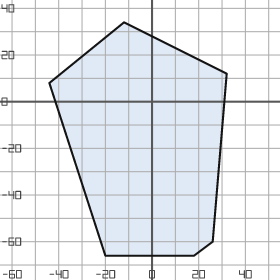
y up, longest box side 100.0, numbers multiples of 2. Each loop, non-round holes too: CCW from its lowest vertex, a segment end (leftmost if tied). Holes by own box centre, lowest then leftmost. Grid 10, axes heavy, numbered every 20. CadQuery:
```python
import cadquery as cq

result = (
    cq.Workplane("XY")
    .moveTo(-20.0, -66.0)
    .lineTo(18.0, -66.0)
    .lineTo(26.0, -60.0)
    .lineTo(32.0, 12.0)
    .lineTo(-12.0, 34.0)
    .lineTo(-44.0, 8.0)
    .close()
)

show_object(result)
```